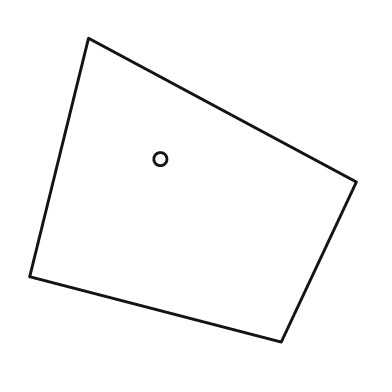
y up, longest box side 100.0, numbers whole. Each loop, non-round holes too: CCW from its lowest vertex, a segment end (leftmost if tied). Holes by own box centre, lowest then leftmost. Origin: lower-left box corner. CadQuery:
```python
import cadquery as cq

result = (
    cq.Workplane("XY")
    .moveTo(77.0, 0.0)
    .lineTo(100.0, 49.0)
    .lineTo(18.0, 93.0)
    .lineTo(0.0, 20.0)
    .close()
    .moveTo(40.0, 56.0)
    .circle(2.0)
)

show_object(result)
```